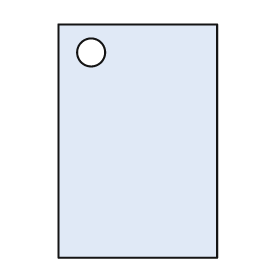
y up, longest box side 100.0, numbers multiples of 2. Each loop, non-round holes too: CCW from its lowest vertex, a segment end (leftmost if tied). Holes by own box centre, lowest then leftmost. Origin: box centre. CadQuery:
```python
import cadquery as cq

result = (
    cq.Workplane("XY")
    .moveTo(-34.0, -50.0)
    .lineTo(34.0, -50.0)
    .lineTo(34.0, 50.0)
    .lineTo(-34.0, 50.0)
    .close()
    .moveTo(-20.0, 38.0)
    .circle(6.0)
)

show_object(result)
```